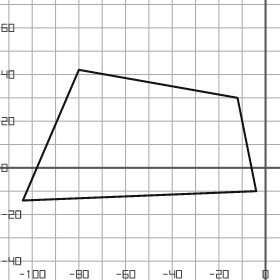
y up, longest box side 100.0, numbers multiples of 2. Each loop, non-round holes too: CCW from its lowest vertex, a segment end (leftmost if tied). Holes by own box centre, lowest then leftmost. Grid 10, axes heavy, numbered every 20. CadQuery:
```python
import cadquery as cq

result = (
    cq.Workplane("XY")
    .moveTo(-104.0, -14.0)
    .lineTo(-4.0, -10.0)
    .lineTo(-12.0, 30.0)
    .lineTo(-80.0, 42.0)
    .close()
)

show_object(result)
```